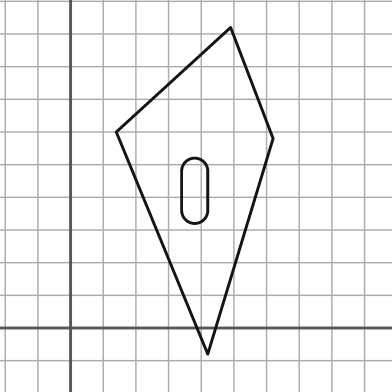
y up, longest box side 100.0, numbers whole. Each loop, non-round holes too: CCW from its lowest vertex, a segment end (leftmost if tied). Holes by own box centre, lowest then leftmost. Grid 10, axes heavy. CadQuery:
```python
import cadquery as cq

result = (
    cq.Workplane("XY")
    .moveTo(42.0, -8.0)
    .lineTo(62.0, 58.0)
    .lineTo(49.0, 92.0)
    .lineTo(14.0, 60.0)
    .close()
    .moveTo(34.0, 36.0)
    .threePointArc((38.0, 32.0), (42.0, 36.0))
    .lineTo(42.0, 48.0)
    .threePointArc((38.0, 52.0), (34.0, 48.0))
    .close()
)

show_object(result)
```